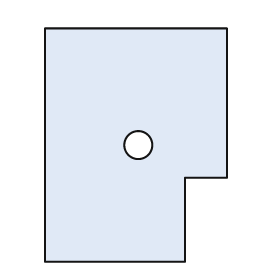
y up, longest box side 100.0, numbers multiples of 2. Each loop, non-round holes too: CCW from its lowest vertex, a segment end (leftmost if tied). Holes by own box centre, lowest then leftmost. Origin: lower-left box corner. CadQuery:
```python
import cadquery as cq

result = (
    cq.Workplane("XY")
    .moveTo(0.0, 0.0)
    .lineTo(60.0, 0.0)
    .lineTo(60.0, 36.0)
    .lineTo(78.0, 36.0)
    .lineTo(78.0, 100.0)
    .lineTo(0.0, 100.0)
    .close()
    .moveTo(40.0, 50.0)
    .circle(6.0)
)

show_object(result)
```